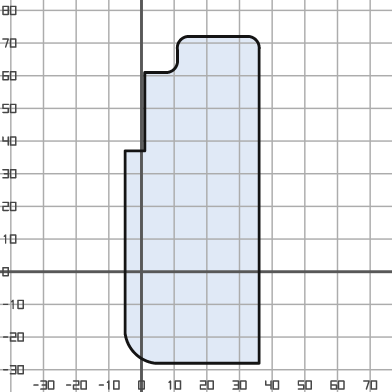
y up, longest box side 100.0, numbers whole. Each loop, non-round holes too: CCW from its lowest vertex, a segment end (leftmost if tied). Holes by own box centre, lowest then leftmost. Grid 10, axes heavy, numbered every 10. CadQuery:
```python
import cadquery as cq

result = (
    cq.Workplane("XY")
    .moveTo(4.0, -28.0)
    .lineTo(36.0, -28.0)
    .lineTo(36.0, 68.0)
    .threePointArc((35.0, 71.0), (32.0, 72.0))
    .lineTo(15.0, 72.0)
    .threePointArc((12.0, 71.0), (11.0, 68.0))
    .lineTo(11.0, 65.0)
    .threePointArc((10.0, 62.0), (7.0, 61.0))
    .lineTo(1.0, 61.0)
    .lineTo(1.0, 37.0)
    .lineTo(-5.0, 37.0)
    .lineTo(-5.0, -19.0)
    .threePointArc((-2.0, -25.0), (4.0, -28.0))
    .close()
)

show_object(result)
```